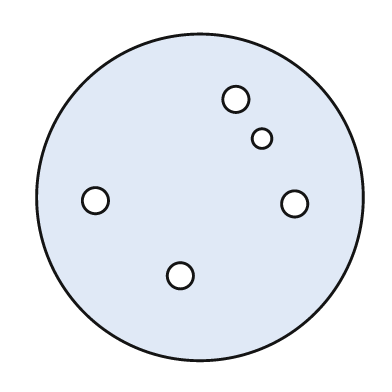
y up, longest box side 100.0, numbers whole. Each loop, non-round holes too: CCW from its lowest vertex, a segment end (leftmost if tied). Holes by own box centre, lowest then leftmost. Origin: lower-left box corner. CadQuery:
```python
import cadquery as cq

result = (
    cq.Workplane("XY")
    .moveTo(50.0, 50.0)
    .circle(50.0)
    .moveTo(44.0, 26.0)
    .circle(4.0)
    .moveTo(79.0, 48.0)
    .circle(4.0)
    .moveTo(18.0, 49.0)
    .circle(4.0)
    .moveTo(69.0, 68.0)
    .circle(3.0)
    .moveTo(61.0, 80.0)
    .circle(4.0)
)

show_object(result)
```